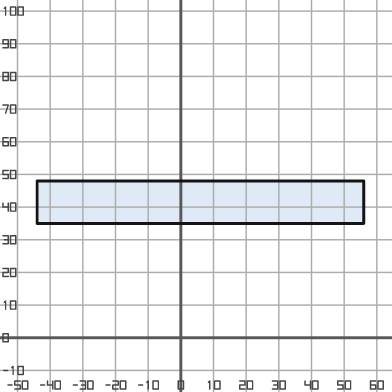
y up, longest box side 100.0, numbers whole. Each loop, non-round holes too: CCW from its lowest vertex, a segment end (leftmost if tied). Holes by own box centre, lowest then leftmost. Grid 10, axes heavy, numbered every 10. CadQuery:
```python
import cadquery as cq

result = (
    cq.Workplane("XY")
    .moveTo(-44.0, 35.0)
    .lineTo(56.0, 35.0)
    .lineTo(56.0, 48.0)
    .lineTo(-44.0, 48.0)
    .close()
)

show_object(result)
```